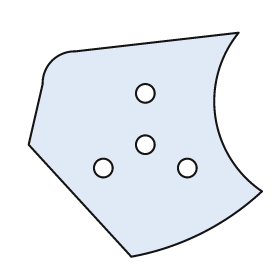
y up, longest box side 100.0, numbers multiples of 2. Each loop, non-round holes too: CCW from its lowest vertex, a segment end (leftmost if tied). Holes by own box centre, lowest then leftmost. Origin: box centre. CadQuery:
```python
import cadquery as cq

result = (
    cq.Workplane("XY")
    .moveTo(-6.0, -48.0)
    .threePointArc((24.0, -38.0), (50.0, -20.0))
    .threePointArc((30.0, 12.0), (40.0, 48.0))
    .lineTo(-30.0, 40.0)
    .threePointArc((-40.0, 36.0), (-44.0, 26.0))
    .lineTo(-50.0, 0.0)
    .close()
    .moveTo(-18.0, -10.0)
    .circle(4.0)
    .moveTo(18.0, -10.0)
    .circle(4.0)
    .moveTo(0.0, 0.0)
    .circle(4.0)
    .moveTo(0.0, 22.0)
    .circle(4.0)
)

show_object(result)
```